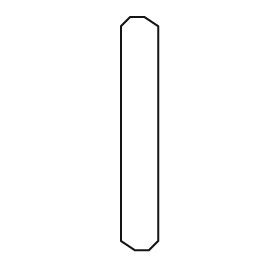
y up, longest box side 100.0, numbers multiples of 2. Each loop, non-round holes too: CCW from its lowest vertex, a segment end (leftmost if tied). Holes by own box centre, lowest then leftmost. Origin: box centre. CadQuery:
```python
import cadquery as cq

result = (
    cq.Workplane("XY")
    .moveTo(-2.0, -50.0)
    .lineTo(4.0, -50.0)
    .lineTo(8.0, -46.0)
    .lineTo(8.0, 46.0)
    .lineTo(2.0, 50.0)
    .lineTo(-4.0, 50.0)
    .lineTo(-8.0, 46.0)
    .lineTo(-8.0, -46.0)
    .close()
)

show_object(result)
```